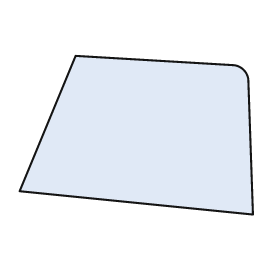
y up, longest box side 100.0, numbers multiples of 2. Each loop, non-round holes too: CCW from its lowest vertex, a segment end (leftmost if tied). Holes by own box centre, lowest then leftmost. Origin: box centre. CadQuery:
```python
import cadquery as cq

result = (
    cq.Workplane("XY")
    .moveTo(50.0, -34.0)
    .lineTo(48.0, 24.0)
    .threePointArc((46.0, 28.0), (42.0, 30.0))
    .lineTo(-26.0, 34.0)
    .lineTo(-50.0, -24.0)
    .close()
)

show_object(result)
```